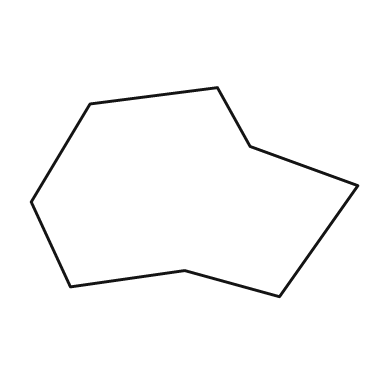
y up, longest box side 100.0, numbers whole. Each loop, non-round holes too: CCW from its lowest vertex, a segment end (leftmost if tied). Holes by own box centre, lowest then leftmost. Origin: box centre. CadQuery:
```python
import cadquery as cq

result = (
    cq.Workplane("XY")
    .moveTo(26.0, -32.0)
    .lineTo(50.0, 2.0)
    .lineTo(17.0, 14.0)
    .lineTo(7.0, 32.0)
    .lineTo(-32.0, 27.0)
    .lineTo(-50.0, -3.0)
    .lineTo(-38.0, -29.0)
    .lineTo(-3.0, -24.0)
    .close()
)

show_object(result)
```